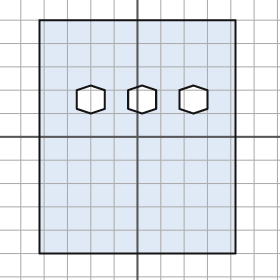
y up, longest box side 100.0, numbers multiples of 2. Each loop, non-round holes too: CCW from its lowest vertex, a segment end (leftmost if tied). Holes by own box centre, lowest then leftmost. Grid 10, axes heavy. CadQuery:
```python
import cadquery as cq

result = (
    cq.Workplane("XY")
    .moveTo(-42.0, -50.0)
    .lineTo(42.0, -50.0)
    .lineTo(42.0, 50.0)
    .lineTo(-42.0, 50.0)
    .close()
    .moveTo(-20.0, 10.0)
    .lineTo(-14.0, 12.0)
    .lineTo(-14.0, 20.0)
    .lineTo(-20.0, 22.0)
    .lineTo(-26.0, 20.0)
    .lineTo(-26.0, 12.0)
    .close()
    .moveTo(2.0, 10.0)
    .lineTo(8.0, 12.0)
    .lineTo(8.0, 20.0)
    .lineTo(2.0, 22.0)
    .lineTo(-4.0, 20.0)
    .lineTo(-4.0, 12.0)
    .close()
    .moveTo(24.0, 10.0)
    .lineTo(30.0, 12.0)
    .lineTo(30.0, 20.0)
    .lineTo(24.0, 22.0)
    .lineTo(18.0, 20.0)
    .lineTo(18.0, 12.0)
    .close()
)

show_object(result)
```